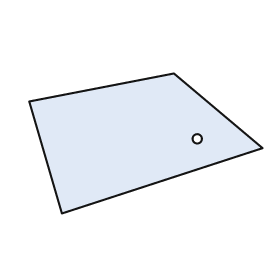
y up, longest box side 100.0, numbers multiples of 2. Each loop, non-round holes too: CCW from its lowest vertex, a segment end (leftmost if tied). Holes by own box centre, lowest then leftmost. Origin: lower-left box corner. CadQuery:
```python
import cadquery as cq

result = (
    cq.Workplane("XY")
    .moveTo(14.0, 0.0)
    .lineTo(100.0, 28.0)
    .lineTo(62.0, 60.0)
    .lineTo(0.0, 48.0)
    .close()
    .moveTo(72.0, 32.0)
    .circle(2.0)
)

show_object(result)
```